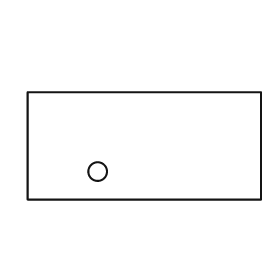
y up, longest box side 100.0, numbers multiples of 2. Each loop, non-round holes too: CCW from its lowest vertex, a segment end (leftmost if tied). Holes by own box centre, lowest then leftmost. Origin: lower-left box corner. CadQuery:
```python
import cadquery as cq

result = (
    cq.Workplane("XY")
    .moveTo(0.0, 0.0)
    .lineTo(100.0, 0.0)
    .lineTo(100.0, 46.0)
    .lineTo(0.0, 46.0)
    .close()
    .moveTo(30.0, 12.0)
    .circle(4.0)
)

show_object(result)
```